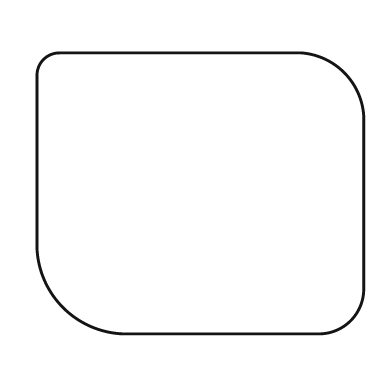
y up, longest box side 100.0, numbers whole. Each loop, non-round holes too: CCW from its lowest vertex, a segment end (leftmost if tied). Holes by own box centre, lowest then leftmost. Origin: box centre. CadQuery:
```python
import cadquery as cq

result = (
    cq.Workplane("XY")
    .moveTo(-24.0, -43.0)
    .lineTo(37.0, -43.0)
    .threePointArc((46.0, -39.0), (50.0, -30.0))
    .lineTo(50.0, 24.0)
    .threePointArc((44.0, 37.0), (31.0, 43.0))
    .lineTo(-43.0, 43.0)
    .threePointArc((-48.0, 41.0), (-50.0, 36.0))
    .lineTo(-50.0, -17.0)
    .threePointArc((-42.0, -35.0), (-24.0, -43.0))
    .close()
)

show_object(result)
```